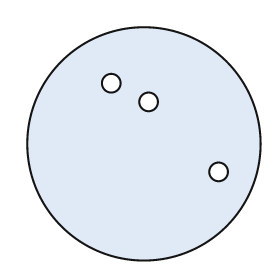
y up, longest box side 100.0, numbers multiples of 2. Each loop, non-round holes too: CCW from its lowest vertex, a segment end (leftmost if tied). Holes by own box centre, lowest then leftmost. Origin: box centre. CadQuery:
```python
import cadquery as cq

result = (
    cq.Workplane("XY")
    .moveTo(0.0, 0.0)
    .circle(50.0)
    .moveTo(32.0, -12.0)
    .circle(4.0)
    .moveTo(2.0, 18.0)
    .circle(4.0)
    .moveTo(-14.0, 26.0)
    .circle(4.0)
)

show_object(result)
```